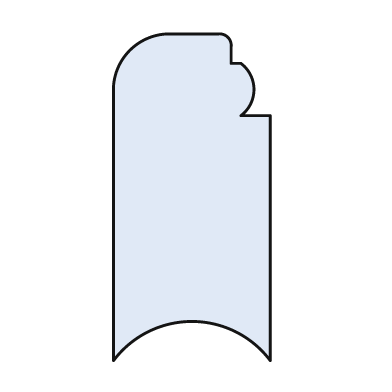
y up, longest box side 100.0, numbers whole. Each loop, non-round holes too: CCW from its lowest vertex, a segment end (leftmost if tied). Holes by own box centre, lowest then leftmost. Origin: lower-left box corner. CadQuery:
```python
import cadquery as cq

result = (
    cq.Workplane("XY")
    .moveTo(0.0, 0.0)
    .threePointArc((24.0, 12.0), (48.0, 0.0))
    .lineTo(48.0, 75.0)
    .lineTo(39.0, 75.0)
    .threePointArc((43.0, 83.0), (39.0, 91.0))
    .lineTo(36.0, 91.0)
    .lineTo(36.0, 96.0)
    .threePointArc((35.0, 99.0), (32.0, 100.0))
    .lineTo(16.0, 100.0)
    .threePointArc((5.0, 95.0), (0.0, 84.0))
    .close()
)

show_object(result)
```